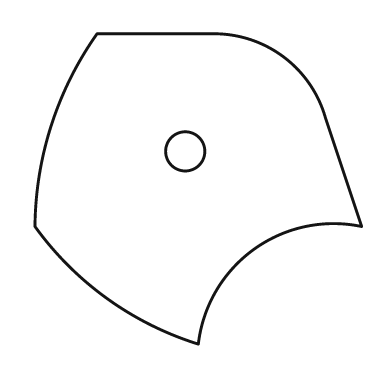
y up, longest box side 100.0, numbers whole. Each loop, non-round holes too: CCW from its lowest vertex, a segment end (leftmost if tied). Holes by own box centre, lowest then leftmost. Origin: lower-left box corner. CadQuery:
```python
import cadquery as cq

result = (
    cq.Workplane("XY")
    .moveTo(50.0, 0.0)
    .threePointArc((67.0, 29.0), (100.0, 36.0))
    .lineTo(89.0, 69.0)
    .threePointArc((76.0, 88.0), (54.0, 95.0))
    .lineTo(19.0, 95.0)
    .threePointArc((5.0, 67.0), (0.0, 36.0))
    .threePointArc((22.0, 14.0), (50.0, 0.0))
    .close()
    .moveTo(46.0, 59.0)
    .circle(6.0)
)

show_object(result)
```